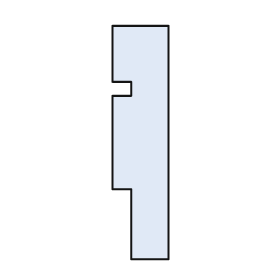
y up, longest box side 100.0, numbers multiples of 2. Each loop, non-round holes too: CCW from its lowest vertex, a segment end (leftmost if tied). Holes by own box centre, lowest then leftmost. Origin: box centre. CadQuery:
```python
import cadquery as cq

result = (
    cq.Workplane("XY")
    .moveTo(-4.0, -50.0)
    .lineTo(12.0, -50.0)
    .lineTo(12.0, 50.0)
    .lineTo(-12.0, 50.0)
    .lineTo(-12.0, 26.0)
    .lineTo(-4.0, 26.0)
    .lineTo(-4.0, 20.0)
    .lineTo(-12.0, 20.0)
    .lineTo(-12.0, -20.0)
    .lineTo(-4.0, -20.0)
    .close()
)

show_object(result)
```